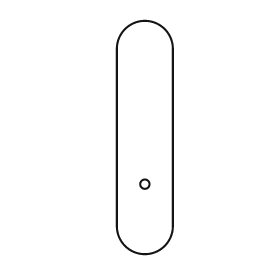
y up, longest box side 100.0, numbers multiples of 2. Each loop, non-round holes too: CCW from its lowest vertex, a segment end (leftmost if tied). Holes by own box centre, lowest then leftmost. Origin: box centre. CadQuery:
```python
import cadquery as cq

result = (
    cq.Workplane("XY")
    .moveTo(-12.0, -38.0)
    .threePointArc((0.0, -50.0), (12.0, -38.0))
    .lineTo(12.0, 38.0)
    .threePointArc((0.0, 50.0), (-12.0, 38.0))
    .close()
    .moveTo(0.0, -20.0)
    .circle(2.0)
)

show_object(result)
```